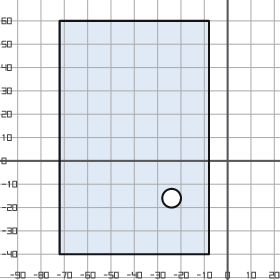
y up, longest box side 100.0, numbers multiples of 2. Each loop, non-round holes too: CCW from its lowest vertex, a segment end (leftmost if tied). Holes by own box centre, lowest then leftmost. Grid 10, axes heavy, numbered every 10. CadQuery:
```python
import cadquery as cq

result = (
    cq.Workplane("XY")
    .moveTo(-72.0, -40.0)
    .lineTo(-8.0, -40.0)
    .lineTo(-8.0, 60.0)
    .lineTo(-72.0, 60.0)
    .close()
    .moveTo(-24.0, -16.0)
    .circle(4.0)
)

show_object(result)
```